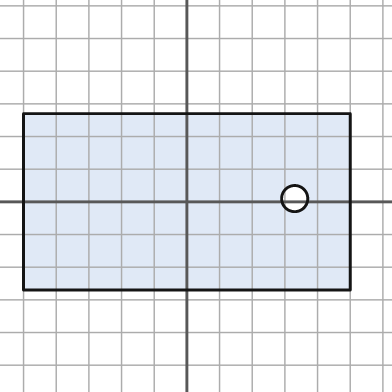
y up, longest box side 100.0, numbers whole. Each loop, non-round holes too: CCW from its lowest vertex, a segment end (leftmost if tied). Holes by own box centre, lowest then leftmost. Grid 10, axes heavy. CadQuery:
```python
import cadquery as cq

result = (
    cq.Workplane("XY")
    .moveTo(-50.0, -27.0)
    .lineTo(50.0, -27.0)
    .lineTo(50.0, 27.0)
    .lineTo(-50.0, 27.0)
    .close()
    .moveTo(33.0, 1.0)
    .circle(4.0)
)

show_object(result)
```